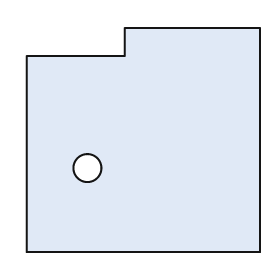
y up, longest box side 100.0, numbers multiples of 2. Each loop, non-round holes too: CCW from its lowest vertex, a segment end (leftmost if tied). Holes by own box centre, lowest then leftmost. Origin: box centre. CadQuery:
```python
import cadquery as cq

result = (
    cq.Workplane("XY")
    .moveTo(-50.0, -48.0)
    .lineTo(50.0, -48.0)
    .lineTo(50.0, 48.0)
    .lineTo(-8.0, 48.0)
    .lineTo(-8.0, 36.0)
    .lineTo(-50.0, 36.0)
    .close()
    .moveTo(-24.0, -12.0)
    .circle(6.0)
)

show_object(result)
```